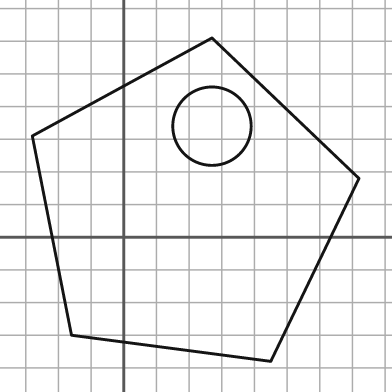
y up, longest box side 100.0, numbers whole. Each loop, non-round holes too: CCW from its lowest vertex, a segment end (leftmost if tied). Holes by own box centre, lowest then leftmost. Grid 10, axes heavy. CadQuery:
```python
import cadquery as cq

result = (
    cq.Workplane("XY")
    .moveTo(45.0, -38.0)
    .lineTo(72.0, 18.0)
    .lineTo(27.0, 61.0)
    .lineTo(-28.0, 31.0)
    .lineTo(-16.0, -30.0)
    .close()
    .moveTo(27.0, 34.0)
    .circle(12.0)
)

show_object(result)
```